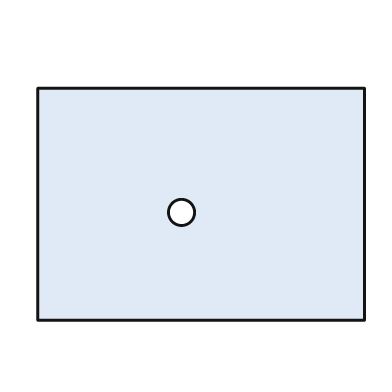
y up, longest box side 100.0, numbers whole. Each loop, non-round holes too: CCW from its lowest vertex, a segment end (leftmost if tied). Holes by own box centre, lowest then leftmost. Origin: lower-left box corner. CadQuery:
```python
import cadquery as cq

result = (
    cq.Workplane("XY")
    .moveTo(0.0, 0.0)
    .lineTo(100.0, 0.0)
    .lineTo(100.0, 71.0)
    .lineTo(0.0, 71.0)
    .close()
    .moveTo(44.0, 33.0)
    .circle(4.0)
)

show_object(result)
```